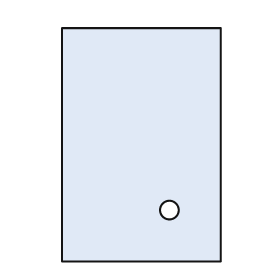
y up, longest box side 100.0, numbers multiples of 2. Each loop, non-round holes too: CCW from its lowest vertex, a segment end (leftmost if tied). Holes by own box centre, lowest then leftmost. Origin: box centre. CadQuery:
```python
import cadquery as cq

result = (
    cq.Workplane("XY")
    .moveTo(-34.0, -50.0)
    .lineTo(34.0, -50.0)
    .lineTo(34.0, 50.0)
    .lineTo(-34.0, 50.0)
    .close()
    .moveTo(12.0, -28.0)
    .circle(4.0)
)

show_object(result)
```